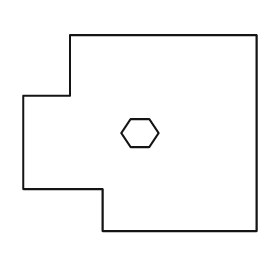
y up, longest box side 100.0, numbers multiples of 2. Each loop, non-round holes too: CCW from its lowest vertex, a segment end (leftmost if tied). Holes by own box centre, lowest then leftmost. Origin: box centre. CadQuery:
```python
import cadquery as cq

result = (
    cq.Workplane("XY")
    .moveTo(-16.0, -42.0)
    .lineTo(50.0, -42.0)
    .lineTo(50.0, 42.0)
    .lineTo(-30.0, 42.0)
    .lineTo(-30.0, 16.0)
    .lineTo(-50.0, 16.0)
    .lineTo(-50.0, -24.0)
    .lineTo(-16.0, -24.0)
    .close()
    .moveTo(-4.0, -6.0)
    .lineTo(4.0, -6.0)
    .lineTo(8.0, 0.0)
    .lineTo(4.0, 6.0)
    .lineTo(-4.0, 6.0)
    .lineTo(-8.0, 0.0)
    .close()
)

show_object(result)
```